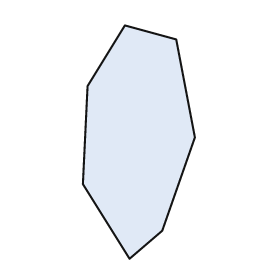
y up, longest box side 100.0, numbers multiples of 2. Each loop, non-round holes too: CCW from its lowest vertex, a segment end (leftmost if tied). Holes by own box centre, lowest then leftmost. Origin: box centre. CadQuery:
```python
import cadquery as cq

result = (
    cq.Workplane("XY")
    .moveTo(-4.0, -50.0)
    .lineTo(10.0, -38.0)
    .lineTo(24.0, 2.0)
    .lineTo(16.0, 44.0)
    .lineTo(-6.0, 50.0)
    .lineTo(-22.0, 24.0)
    .lineTo(-24.0, -18.0)
    .close()
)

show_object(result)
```